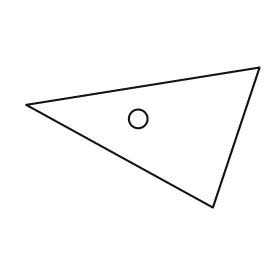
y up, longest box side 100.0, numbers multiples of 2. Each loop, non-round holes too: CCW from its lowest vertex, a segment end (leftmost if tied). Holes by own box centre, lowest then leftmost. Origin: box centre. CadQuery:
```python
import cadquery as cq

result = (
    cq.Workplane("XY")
    .moveTo(30.0, -30.0)
    .lineTo(50.0, 30.0)
    .lineTo(-50.0, 14.0)
    .close()
    .moveTo(-2.0, 8.0)
    .circle(4.0)
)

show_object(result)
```